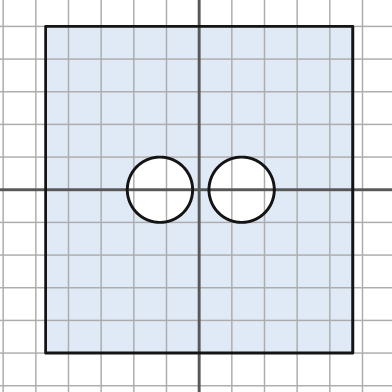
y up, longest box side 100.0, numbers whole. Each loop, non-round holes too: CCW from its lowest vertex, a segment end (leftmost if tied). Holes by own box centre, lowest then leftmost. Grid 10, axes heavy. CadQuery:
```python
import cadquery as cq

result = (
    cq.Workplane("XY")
    .moveTo(-47.0, -50.0)
    .lineTo(47.0, -50.0)
    .lineTo(47.0, 50.0)
    .lineTo(-47.0, 50.0)
    .close()
    .moveTo(-12.0, 0.0)
    .circle(10.0)
    .moveTo(13.0, 0.0)
    .circle(10.0)
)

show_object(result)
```